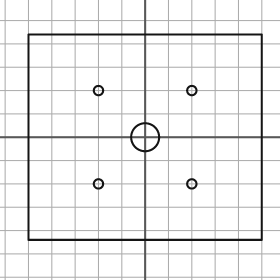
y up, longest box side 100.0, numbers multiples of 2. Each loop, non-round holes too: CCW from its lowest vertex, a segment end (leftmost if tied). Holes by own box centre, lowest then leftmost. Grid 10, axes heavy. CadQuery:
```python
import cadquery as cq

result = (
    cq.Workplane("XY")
    .moveTo(-50.0, -44.0)
    .lineTo(50.0, -44.0)
    .lineTo(50.0, 44.0)
    .lineTo(-50.0, 44.0)
    .close()
    .moveTo(-20.0, -20.0)
    .circle(2.0)
    .moveTo(20.0, -20.0)
    .circle(2.0)
    .moveTo(0.0, 0.0)
    .circle(6.0)
    .moveTo(-20.0, 20.0)
    .circle(2.0)
    .moveTo(20.0, 20.0)
    .circle(2.0)
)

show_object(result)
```